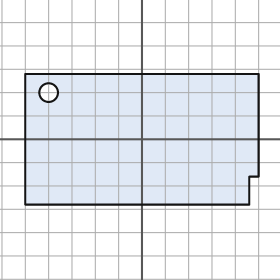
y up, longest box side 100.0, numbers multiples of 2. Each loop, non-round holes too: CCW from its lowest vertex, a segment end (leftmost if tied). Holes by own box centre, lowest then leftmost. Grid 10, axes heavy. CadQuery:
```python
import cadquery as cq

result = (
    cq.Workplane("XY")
    .moveTo(-50.0, -28.0)
    .lineTo(46.0, -28.0)
    .lineTo(46.0, -16.0)
    .lineTo(50.0, -16.0)
    .lineTo(50.0, 28.0)
    .lineTo(-50.0, 28.0)
    .close()
    .moveTo(-40.0, 20.0)
    .circle(4.0)
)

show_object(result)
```